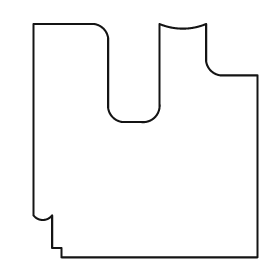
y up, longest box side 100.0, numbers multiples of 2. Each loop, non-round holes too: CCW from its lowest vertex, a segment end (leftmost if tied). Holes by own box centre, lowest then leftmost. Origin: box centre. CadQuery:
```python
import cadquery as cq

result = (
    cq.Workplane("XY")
    .moveTo(-36.0, -50.0)
    .lineTo(48.0, -50.0)
    .lineTo(48.0, 28.0)
    .lineTo(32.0, 28.0)
    .threePointArc((28.0, 30.0), (26.0, 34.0))
    .lineTo(26.0, 50.0)
    .threePointArc((16.0, 48.0), (6.0, 50.0))
    .lineTo(6.0, 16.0)
    .threePointArc((4.0, 10.0), (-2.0, 8.0))
    .lineTo(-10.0, 8.0)
    .threePointArc((-14.0, 10.0), (-16.0, 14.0))
    .lineTo(-16.0, 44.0)
    .threePointArc((-18.0, 48.0), (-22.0, 50.0))
    .lineTo(-48.0, 50.0)
    .lineTo(-48.0, -32.0)
    .threePointArc((-44.0, -34.0), (-40.0, -32.0))
    .lineTo(-40.0, -46.0)
    .lineTo(-36.0, -46.0)
    .close()
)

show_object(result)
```